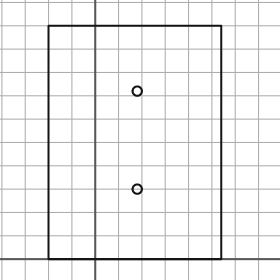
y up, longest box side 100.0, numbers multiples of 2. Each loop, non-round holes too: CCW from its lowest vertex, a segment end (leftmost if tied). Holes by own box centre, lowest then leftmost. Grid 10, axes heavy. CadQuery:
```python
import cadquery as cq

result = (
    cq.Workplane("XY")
    .moveTo(-20.0, 0.0)
    .lineTo(54.0, 0.0)
    .lineTo(54.0, 100.0)
    .lineTo(-20.0, 100.0)
    .close()
    .moveTo(18.0, 30.0)
    .circle(2.0)
    .moveTo(18.0, 72.0)
    .circle(2.0)
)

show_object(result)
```